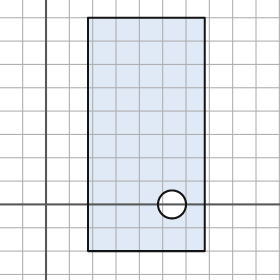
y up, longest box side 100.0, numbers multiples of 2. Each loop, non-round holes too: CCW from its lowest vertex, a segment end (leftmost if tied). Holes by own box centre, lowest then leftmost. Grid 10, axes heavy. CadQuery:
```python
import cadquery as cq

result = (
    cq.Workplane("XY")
    .moveTo(18.0, -20.0)
    .lineTo(68.0, -20.0)
    .lineTo(68.0, 80.0)
    .lineTo(18.0, 80.0)
    .close()
    .moveTo(54.0, 0.0)
    .circle(6.0)
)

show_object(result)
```